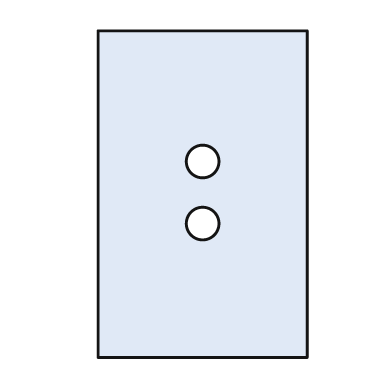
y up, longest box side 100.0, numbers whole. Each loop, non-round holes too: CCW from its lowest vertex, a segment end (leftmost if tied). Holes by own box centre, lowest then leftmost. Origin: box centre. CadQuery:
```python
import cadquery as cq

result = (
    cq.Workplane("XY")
    .moveTo(-32.0, -50.0)
    .lineTo(32.0, -50.0)
    .lineTo(32.0, 50.0)
    .lineTo(-32.0, 50.0)
    .close()
    .moveTo(0.0, -9.0)
    .circle(5.0)
    .moveTo(0.0, 10.0)
    .circle(5.0)
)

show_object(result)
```